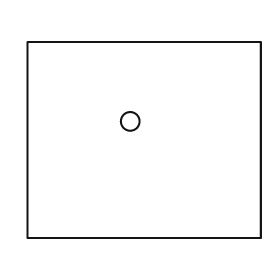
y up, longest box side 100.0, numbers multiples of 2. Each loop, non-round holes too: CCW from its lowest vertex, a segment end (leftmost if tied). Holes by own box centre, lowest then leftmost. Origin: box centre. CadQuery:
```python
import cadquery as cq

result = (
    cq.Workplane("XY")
    .moveTo(-50.0, -42.0)
    .lineTo(50.0, -42.0)
    .lineTo(50.0, 42.0)
    .lineTo(-50.0, 42.0)
    .close()
    .moveTo(-6.0, 8.0)
    .circle(4.0)
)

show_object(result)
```